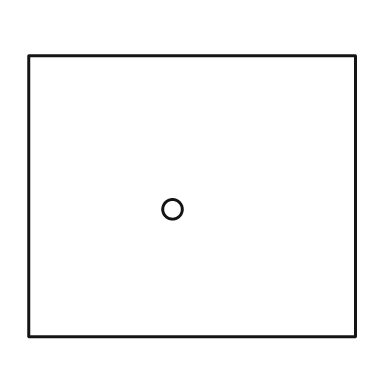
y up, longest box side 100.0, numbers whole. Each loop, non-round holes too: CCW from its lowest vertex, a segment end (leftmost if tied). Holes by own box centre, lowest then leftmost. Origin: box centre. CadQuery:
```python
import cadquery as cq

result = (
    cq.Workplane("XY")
    .moveTo(-50.0, -43.0)
    .lineTo(50.0, -43.0)
    .lineTo(50.0, 43.0)
    .lineTo(-50.0, 43.0)
    .close()
    .moveTo(-6.0, -4.0)
    .circle(3.0)
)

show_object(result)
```